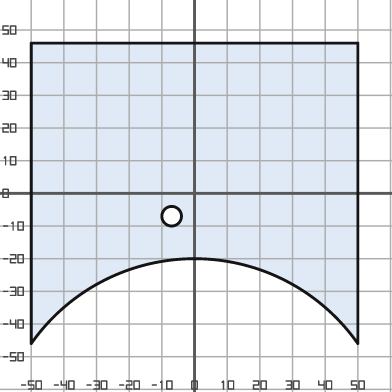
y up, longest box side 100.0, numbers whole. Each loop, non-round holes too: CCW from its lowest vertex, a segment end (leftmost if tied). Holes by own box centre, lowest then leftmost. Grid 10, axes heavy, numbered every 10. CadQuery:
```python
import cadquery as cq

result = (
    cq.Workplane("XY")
    .moveTo(-50.0, -46.0)
    .threePointArc((0.0, -20.0), (50.0, -46.0))
    .lineTo(50.0, 46.0)
    .lineTo(-50.0, 46.0)
    .close()
    .moveTo(-7.0, -7.0)
    .circle(3.0)
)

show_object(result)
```